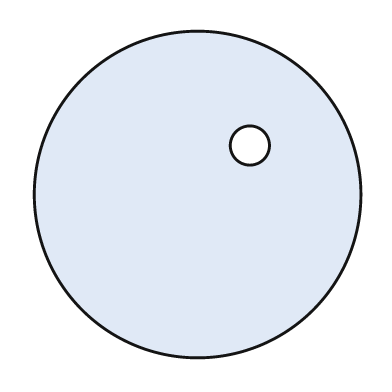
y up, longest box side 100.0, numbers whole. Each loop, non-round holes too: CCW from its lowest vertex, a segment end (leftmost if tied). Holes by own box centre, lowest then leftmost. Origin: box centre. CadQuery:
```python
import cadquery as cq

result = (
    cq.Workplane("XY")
    .moveTo(0.0, 0.0)
    .circle(50.0)
    .moveTo(16.0, 15.0)
    .circle(6.0)
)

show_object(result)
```